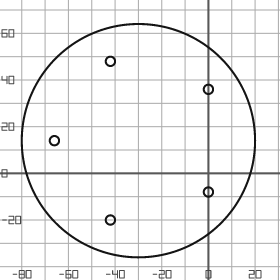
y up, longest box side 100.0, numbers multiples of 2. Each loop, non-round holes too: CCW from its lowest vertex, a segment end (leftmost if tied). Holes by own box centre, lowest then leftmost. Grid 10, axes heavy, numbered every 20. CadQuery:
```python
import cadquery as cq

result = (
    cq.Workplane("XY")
    .moveTo(-30.0, 14.0)
    .circle(50.0)
    .moveTo(-42.0, -20.0)
    .circle(2.0)
    .moveTo(0.0, -8.0)
    .circle(2.0)
    .moveTo(-66.0, 14.0)
    .circle(2.0)
    .moveTo(0.0, 36.0)
    .circle(2.0)
    .moveTo(-42.0, 48.0)
    .circle(2.0)
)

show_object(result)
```